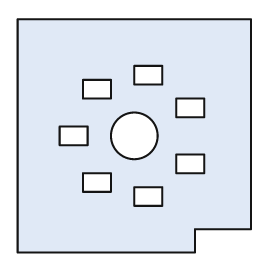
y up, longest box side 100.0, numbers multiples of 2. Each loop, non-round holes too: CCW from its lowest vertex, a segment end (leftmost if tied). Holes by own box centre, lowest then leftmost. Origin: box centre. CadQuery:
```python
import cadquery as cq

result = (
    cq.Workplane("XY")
    .moveTo(-50.0, -50.0)
    .lineTo(26.0, -50.0)
    .lineTo(26.0, -40.0)
    .lineTo(50.0, -40.0)
    .lineTo(50.0, 50.0)
    .lineTo(-50.0, 50.0)
    .close()
    .moveTo(0.0, -30.0)
    .lineTo(12.0, -30.0)
    .lineTo(12.0, -22.0)
    .lineTo(0.0, -22.0)
    .close()
    .moveTo(-22.0, -24.0)
    .lineTo(-10.0, -24.0)
    .lineTo(-10.0, -16.0)
    .lineTo(-22.0, -16.0)
    .close()
    .moveTo(18.0, -16.0)
    .lineTo(30.0, -16.0)
    .lineTo(30.0, -8.0)
    .lineTo(18.0, -8.0)
    .close()
    .moveTo(-32.0, -4.0)
    .lineTo(-20.0, -4.0)
    .lineTo(-20.0, 4.0)
    .lineTo(-32.0, 4.0)
    .close()
    .moveTo(0.0, 0.0)
    .circle(10.0)
    .moveTo(18.0, 8.0)
    .lineTo(30.0, 8.0)
    .lineTo(30.0, 16.0)
    .lineTo(18.0, 16.0)
    .close()
    .moveTo(-22.0, 16.0)
    .lineTo(-10.0, 16.0)
    .lineTo(-10.0, 24.0)
    .lineTo(-22.0, 24.0)
    .close()
    .moveTo(0.0, 22.0)
    .lineTo(12.0, 22.0)
    .lineTo(12.0, 30.0)
    .lineTo(0.0, 30.0)
    .close()
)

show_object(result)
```